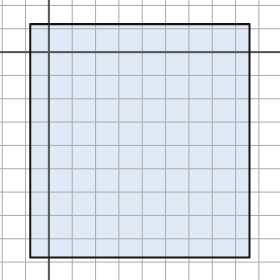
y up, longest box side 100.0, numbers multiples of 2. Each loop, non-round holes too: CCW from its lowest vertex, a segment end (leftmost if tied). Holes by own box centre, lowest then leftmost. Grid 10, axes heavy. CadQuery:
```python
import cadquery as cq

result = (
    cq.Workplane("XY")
    .moveTo(-8.0, -88.0)
    .lineTo(86.0, -88.0)
    .lineTo(86.0, 12.0)
    .lineTo(-8.0, 12.0)
    .close()
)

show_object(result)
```